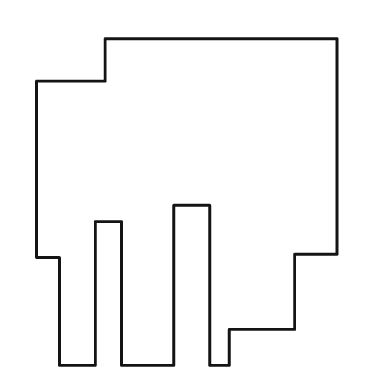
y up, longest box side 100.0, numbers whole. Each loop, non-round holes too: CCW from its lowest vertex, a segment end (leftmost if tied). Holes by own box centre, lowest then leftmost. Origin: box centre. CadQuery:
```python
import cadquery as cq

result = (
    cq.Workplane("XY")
    .moveTo(-39.0, -50.0)
    .lineTo(-28.0, -50.0)
    .lineTo(-28.0, -6.0)
    .lineTo(-20.0, -6.0)
    .lineTo(-20.0, -50.0)
    .lineTo(-4.0, -50.0)
    .lineTo(-4.0, -1.0)
    .lineTo(7.0, -1.0)
    .lineTo(7.0, -50.0)
    .lineTo(13.0, -50.0)
    .lineTo(13.0, -39.0)
    .lineTo(33.0, -39.0)
    .lineTo(33.0, -16.0)
    .lineTo(46.0, -16.0)
    .lineTo(46.0, 50.0)
    .lineTo(-25.0, 50.0)
    .lineTo(-25.0, 37.0)
    .lineTo(-46.0, 37.0)
    .lineTo(-46.0, -17.0)
    .lineTo(-39.0, -17.0)
    .close()
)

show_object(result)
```